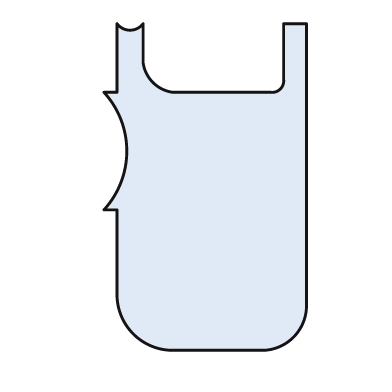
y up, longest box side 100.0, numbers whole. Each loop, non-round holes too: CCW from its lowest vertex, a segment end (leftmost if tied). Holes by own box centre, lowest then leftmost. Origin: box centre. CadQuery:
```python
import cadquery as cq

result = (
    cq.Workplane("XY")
    .moveTo(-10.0, -50.0)
    .lineTo(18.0, -50.0)
    .threePointArc((27.0, -46.0), (31.0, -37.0))
    .lineTo(31.0, 50.0)
    .lineTo(24.0, 50.0)
    .lineTo(24.0, 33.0)
    .threePointArc((23.0, 30.0), (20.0, 29.0))
    .lineTo(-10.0, 29.0)
    .threePointArc((-16.0, 32.0), (-19.0, 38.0))
    .lineTo(-19.0, 50.0)
    .threePointArc((-23.0, 48.0), (-27.0, 50.0))
    .lineTo(-27.0, 29.0)
    .lineTo(-31.0, 29.0)
    .threePointArc((-24.0, 11.0), (-31.0, -7.0))
    .lineTo(-27.0, -7.0)
    .lineTo(-27.0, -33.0)
    .threePointArc((-22.0, -45.0), (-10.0, -50.0))
    .close()
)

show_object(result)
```